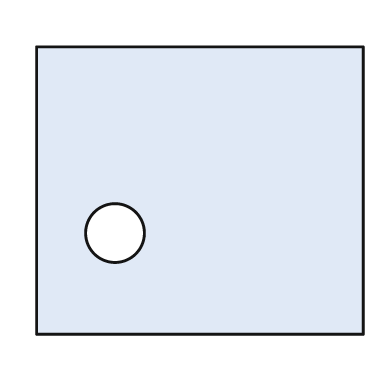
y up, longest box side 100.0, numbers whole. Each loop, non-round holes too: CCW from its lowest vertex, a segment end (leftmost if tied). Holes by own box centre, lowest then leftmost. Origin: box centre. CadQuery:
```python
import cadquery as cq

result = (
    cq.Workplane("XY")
    .moveTo(-50.0, -44.0)
    .lineTo(50.0, -44.0)
    .lineTo(50.0, 44.0)
    .lineTo(-50.0, 44.0)
    .close()
    .moveTo(-26.0, -13.0)
    .circle(9.0)
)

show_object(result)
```